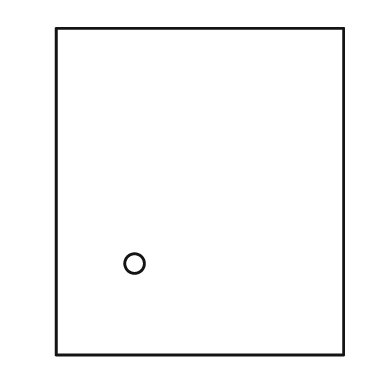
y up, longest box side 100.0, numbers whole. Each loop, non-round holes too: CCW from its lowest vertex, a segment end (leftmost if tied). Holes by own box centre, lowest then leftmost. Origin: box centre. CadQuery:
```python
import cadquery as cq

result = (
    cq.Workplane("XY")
    .moveTo(-44.0, -50.0)
    .lineTo(44.0, -50.0)
    .lineTo(44.0, 50.0)
    .lineTo(-44.0, 50.0)
    .close()
    .moveTo(-20.0, -22.0)
    .circle(3.0)
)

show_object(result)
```